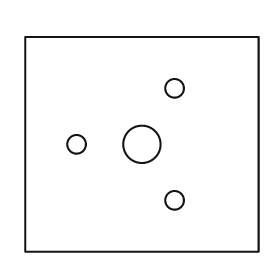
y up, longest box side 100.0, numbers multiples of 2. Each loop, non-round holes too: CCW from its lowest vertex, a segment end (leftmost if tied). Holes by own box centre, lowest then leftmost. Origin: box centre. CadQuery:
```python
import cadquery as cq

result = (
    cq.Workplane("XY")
    .moveTo(-50.0, -46.0)
    .lineTo(50.0, -46.0)
    .lineTo(50.0, 46.0)
    .lineTo(-50.0, 46.0)
    .close()
    .moveTo(14.0, -24.0)
    .circle(4.0)
    .moveTo(-28.0, 0.0)
    .circle(4.0)
    .moveTo(0.0, 0.0)
    .circle(8.0)
    .moveTo(14.0, 24.0)
    .circle(4.0)
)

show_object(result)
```